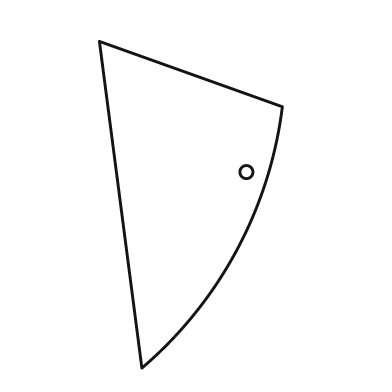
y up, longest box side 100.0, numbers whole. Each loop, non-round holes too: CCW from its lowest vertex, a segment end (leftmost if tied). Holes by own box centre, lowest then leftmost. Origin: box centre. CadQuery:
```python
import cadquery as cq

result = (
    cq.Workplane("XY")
    .moveTo(-15.0, -50.0)
    .threePointArc((14.0, -14.0), (28.0, 30.0))
    .lineTo(-28.0, 50.0)
    .close()
    .moveTo(17.0, 10.0)
    .circle(2.0)
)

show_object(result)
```